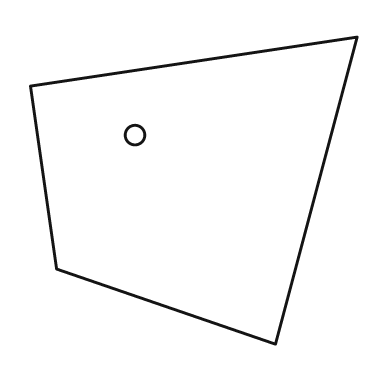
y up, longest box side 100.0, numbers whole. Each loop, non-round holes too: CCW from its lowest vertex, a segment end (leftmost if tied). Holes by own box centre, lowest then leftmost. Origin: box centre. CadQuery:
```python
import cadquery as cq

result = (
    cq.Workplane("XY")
    .moveTo(25.0, -47.0)
    .lineTo(50.0, 47.0)
    .lineTo(-50.0, 32.0)
    .lineTo(-42.0, -24.0)
    .close()
    .moveTo(-18.0, 17.0)
    .circle(3.0)
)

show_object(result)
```